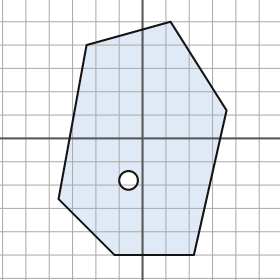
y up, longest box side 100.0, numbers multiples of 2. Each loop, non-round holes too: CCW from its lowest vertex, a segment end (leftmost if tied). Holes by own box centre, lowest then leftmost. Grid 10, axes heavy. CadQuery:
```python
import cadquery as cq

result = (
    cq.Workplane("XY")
    .moveTo(-12.0, -50.0)
    .lineTo(22.0, -50.0)
    .lineTo(36.0, 12.0)
    .lineTo(12.0, 50.0)
    .lineTo(-24.0, 40.0)
    .lineTo(-36.0, -26.0)
    .close()
    .moveTo(-6.0, -18.0)
    .circle(4.0)
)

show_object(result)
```